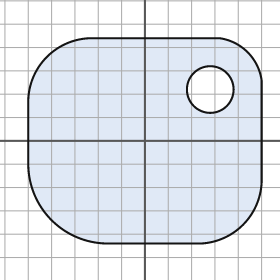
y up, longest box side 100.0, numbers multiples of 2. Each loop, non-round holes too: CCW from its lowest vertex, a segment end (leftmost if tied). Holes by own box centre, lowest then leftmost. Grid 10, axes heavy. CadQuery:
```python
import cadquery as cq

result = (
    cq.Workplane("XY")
    .moveTo(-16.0, -44.0)
    .lineTo(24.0, -44.0)
    .threePointArc((42.0, -36.0), (50.0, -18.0))
    .lineTo(50.0, 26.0)
    .threePointArc((44.0, 38.0), (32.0, 44.0))
    .lineTo(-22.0, 44.0)
    .threePointArc((-42.0, 36.0), (-50.0, 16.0))
    .lineTo(-50.0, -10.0)
    .threePointArc((-40.0, -34.0), (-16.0, -44.0))
    .close()
    .moveTo(28.0, 22.0)
    .circle(10.0)
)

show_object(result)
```